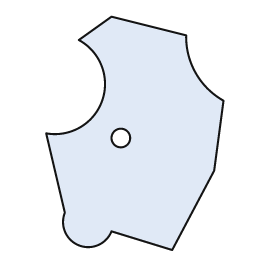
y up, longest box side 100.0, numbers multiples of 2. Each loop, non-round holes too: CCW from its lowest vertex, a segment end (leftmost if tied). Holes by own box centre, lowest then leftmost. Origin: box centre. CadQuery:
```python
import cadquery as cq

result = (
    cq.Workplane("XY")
    .moveTo(16.0, -50.0)
    .lineTo(34.0, -16.0)
    .lineTo(38.0, 14.0)
    .threePointArc((26.0, 26.0), (22.0, 42.0))
    .lineTo(-10.0, 50.0)
    .lineTo(-24.0, 40.0)
    .threePointArc((-14.0, 14.0), (-38.0, 0.0))
    .lineTo(-30.0, -34.0)
    .threePointArc((-24.0, -48.0), (-10.0, -42.0))
    .close()
    .moveTo(-6.0, -2.0)
    .circle(4.0)
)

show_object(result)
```